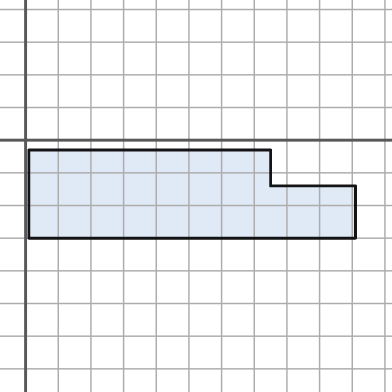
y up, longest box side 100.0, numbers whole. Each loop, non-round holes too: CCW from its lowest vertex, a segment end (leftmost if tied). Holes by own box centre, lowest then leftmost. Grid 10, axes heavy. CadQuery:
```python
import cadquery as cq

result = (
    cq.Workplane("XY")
    .moveTo(1.0, -30.0)
    .lineTo(101.0, -30.0)
    .lineTo(101.0, -14.0)
    .lineTo(75.0, -14.0)
    .lineTo(75.0, -3.0)
    .lineTo(1.0, -3.0)
    .close()
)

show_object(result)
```